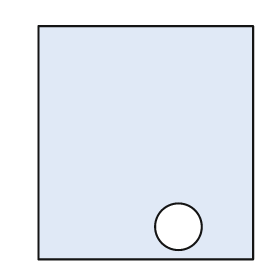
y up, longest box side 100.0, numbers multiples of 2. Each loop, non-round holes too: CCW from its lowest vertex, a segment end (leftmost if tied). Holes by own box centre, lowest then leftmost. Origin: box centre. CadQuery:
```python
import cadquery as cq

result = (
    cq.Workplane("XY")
    .moveTo(-46.0, -50.0)
    .lineTo(46.0, -50.0)
    .lineTo(46.0, 50.0)
    .lineTo(-46.0, 50.0)
    .close()
    .moveTo(14.0, -36.0)
    .circle(10.0)
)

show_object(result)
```